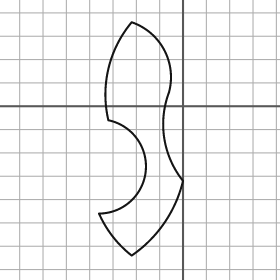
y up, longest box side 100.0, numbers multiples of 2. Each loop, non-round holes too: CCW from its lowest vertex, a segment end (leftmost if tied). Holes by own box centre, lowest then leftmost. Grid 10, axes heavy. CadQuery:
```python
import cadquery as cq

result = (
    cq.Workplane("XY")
    .moveTo(-22.0, -64.0)
    .threePointArc((-8.0, -50.0), (0.0, -32.0))
    .threePointArc((-8.0, -14.0), (-6.0, 6.0))
    .threePointArc((-8.0, 24.0), (-22.0, 36.0))
    .threePointArc((-32.0, 16.0), (-32.0, -6.0))
    .threePointArc((-16.0, -28.0), (-36.0, -46.0))
    .threePointArc((-30.0, -56.0), (-22.0, -64.0))
    .close()
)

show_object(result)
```